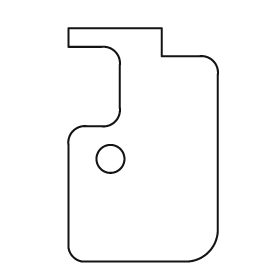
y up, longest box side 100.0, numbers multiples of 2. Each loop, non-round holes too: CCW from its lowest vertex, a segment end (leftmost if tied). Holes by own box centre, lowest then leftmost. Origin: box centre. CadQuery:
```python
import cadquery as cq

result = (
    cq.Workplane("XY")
    .moveTo(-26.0, -50.0)
    .lineTo(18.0, -50.0)
    .threePointArc((28.0, -46.0), (32.0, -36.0))
    .lineTo(32.0, 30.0)
    .threePointArc((30.0, 36.0), (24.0, 38.0))
    .lineTo(8.0, 38.0)
    .lineTo(8.0, 50.0)
    .lineTo(-32.0, 50.0)
    .lineTo(-32.0, 42.0)
    .lineTo(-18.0, 42.0)
    .threePointArc((-12.0, 40.0), (-10.0, 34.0))
    .lineTo(-10.0, 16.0)
    .threePointArc((-12.0, 10.0), (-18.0, 8.0))
    .lineTo(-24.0, 8.0)
    .threePointArc((-30.0, 6.0), (-32.0, 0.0))
    .lineTo(-32.0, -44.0)
    .threePointArc((-30.0, -48.0), (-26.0, -50.0))
    .close()
    .moveTo(-14.0, -6.0)
    .circle(6.0)
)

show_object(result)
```